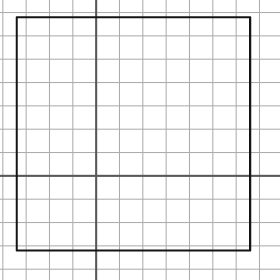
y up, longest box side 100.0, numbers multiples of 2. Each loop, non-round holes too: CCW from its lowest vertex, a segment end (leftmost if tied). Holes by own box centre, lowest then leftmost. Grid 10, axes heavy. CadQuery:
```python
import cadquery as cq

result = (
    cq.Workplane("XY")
    .moveTo(-34.0, -32.0)
    .lineTo(66.0, -32.0)
    .lineTo(66.0, 68.0)
    .lineTo(-34.0, 68.0)
    .close()
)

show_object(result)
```